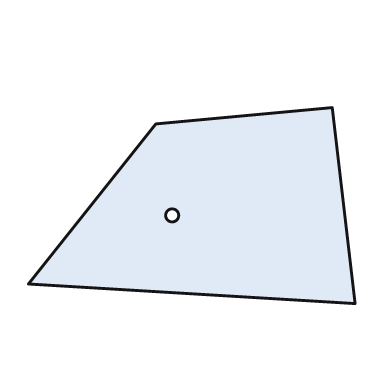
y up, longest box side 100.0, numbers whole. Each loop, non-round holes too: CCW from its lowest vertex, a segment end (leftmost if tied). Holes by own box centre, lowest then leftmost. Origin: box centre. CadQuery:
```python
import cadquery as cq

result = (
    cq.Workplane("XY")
    .moveTo(50.0, -30.0)
    .lineTo(43.0, 30.0)
    .lineTo(-11.0, 25.0)
    .lineTo(-50.0, -24.0)
    .close()
    .moveTo(-6.0, -3.0)
    .circle(2.0)
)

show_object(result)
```